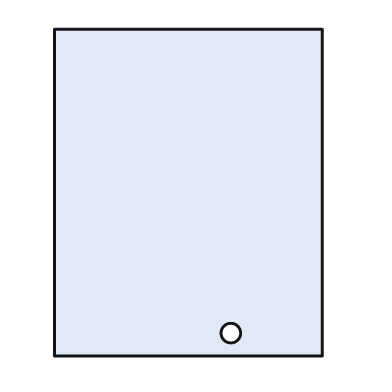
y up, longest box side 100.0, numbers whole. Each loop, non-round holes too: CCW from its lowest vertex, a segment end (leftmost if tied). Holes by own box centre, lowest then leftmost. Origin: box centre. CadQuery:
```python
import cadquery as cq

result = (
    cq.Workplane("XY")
    .moveTo(-41.0, -50.0)
    .lineTo(41.0, -50.0)
    .lineTo(41.0, 50.0)
    .lineTo(-41.0, 50.0)
    .close()
    .moveTo(13.0, -43.0)
    .circle(3.0)
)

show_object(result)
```